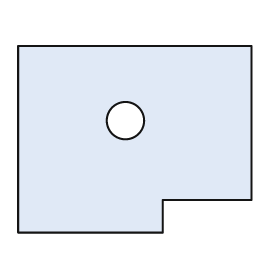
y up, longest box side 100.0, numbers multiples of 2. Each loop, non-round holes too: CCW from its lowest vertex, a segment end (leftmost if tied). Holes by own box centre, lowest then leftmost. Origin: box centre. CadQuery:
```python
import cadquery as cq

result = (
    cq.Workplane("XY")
    .moveTo(-50.0, -40.0)
    .lineTo(12.0, -40.0)
    .lineTo(12.0, -26.0)
    .lineTo(50.0, -26.0)
    .lineTo(50.0, 40.0)
    .lineTo(-50.0, 40.0)
    .close()
    .moveTo(-4.0, 8.0)
    .circle(8.0)
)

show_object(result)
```